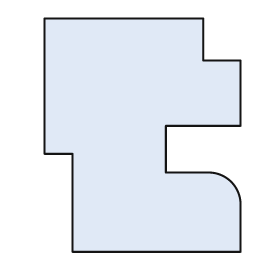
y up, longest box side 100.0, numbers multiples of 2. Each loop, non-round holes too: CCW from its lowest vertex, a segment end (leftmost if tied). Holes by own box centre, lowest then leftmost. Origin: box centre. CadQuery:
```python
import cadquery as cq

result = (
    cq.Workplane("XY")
    .moveTo(-30.0, -50.0)
    .lineTo(42.0, -50.0)
    .lineTo(42.0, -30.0)
    .threePointArc((38.0, -20.0), (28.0, -16.0))
    .lineTo(10.0, -16.0)
    .lineTo(10.0, 4.0)
    .lineTo(42.0, 4.0)
    .lineTo(42.0, 32.0)
    .lineTo(26.0, 32.0)
    .lineTo(26.0, 50.0)
    .lineTo(-42.0, 50.0)
    .lineTo(-42.0, -8.0)
    .lineTo(-30.0, -8.0)
    .close()
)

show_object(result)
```